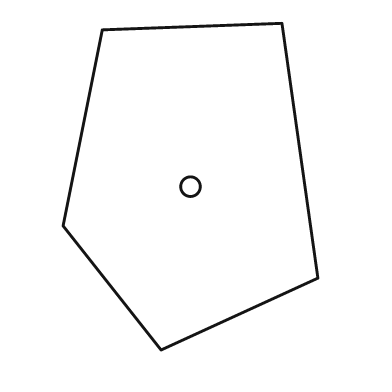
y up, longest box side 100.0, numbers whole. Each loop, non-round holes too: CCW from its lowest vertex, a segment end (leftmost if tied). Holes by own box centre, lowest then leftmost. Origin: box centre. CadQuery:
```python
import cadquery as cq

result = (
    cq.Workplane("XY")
    .moveTo(-9.0, -50.0)
    .lineTo(39.0, -28.0)
    .lineTo(28.0, 50.0)
    .lineTo(-27.0, 48.0)
    .lineTo(-39.0, -12.0)
    .close()
    .moveTo(0.0, 0.0)
    .circle(3.0)
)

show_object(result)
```